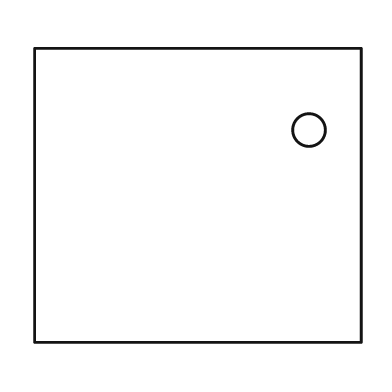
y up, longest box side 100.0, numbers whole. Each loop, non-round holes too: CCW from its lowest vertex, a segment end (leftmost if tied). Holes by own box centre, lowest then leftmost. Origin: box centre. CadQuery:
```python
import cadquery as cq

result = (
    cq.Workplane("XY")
    .moveTo(-50.0, -45.0)
    .lineTo(50.0, -45.0)
    .lineTo(50.0, 45.0)
    .lineTo(-50.0, 45.0)
    .close()
    .moveTo(34.0, 20.0)
    .circle(5.0)
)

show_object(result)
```